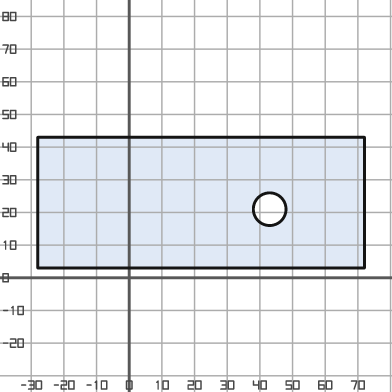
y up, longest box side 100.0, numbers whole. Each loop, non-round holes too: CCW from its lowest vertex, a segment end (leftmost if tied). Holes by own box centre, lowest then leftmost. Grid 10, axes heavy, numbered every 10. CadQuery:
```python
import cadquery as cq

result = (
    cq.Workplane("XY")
    .moveTo(-28.0, 3.0)
    .lineTo(72.0, 3.0)
    .lineTo(72.0, 43.0)
    .lineTo(-28.0, 43.0)
    .close()
    .moveTo(43.0, 21.0)
    .circle(5.0)
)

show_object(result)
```